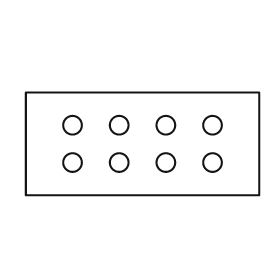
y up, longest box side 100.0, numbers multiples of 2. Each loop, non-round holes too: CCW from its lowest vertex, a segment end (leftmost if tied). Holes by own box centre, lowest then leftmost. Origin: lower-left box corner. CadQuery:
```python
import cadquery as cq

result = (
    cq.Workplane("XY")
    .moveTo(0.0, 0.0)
    .lineTo(100.0, 0.0)
    .lineTo(100.0, 44.0)
    .lineTo(0.0, 44.0)
    .close()
    .moveTo(20.0, 14.0)
    .circle(4.0)
    .moveTo(40.0, 14.0)
    .circle(4.0)
    .moveTo(60.0, 14.0)
    .circle(4.0)
    .moveTo(80.0, 14.0)
    .circle(4.0)
    .moveTo(20.0, 30.0)
    .circle(4.0)
    .moveTo(40.0, 30.0)
    .circle(4.0)
    .moveTo(60.0, 30.0)
    .circle(4.0)
    .moveTo(80.0, 30.0)
    .circle(4.0)
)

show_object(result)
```